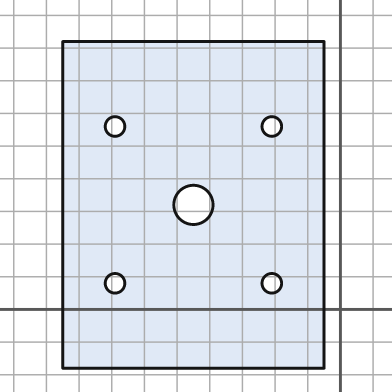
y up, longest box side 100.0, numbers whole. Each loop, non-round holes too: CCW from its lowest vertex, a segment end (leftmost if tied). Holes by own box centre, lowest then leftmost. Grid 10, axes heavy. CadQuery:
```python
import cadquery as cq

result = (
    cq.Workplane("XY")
    .moveTo(-85.0, -18.0)
    .lineTo(-5.0, -18.0)
    .lineTo(-5.0, 82.0)
    .lineTo(-85.0, 82.0)
    .close()
    .moveTo(-69.0, 8.0)
    .circle(3.0)
    .moveTo(-21.0, 8.0)
    .circle(3.0)
    .moveTo(-45.0, 32.0)
    .circle(6.0)
    .moveTo(-69.0, 56.0)
    .circle(3.0)
    .moveTo(-21.0, 56.0)
    .circle(3.0)
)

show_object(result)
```